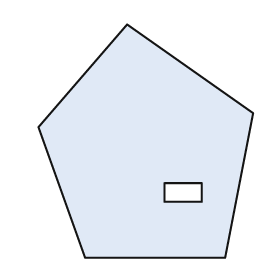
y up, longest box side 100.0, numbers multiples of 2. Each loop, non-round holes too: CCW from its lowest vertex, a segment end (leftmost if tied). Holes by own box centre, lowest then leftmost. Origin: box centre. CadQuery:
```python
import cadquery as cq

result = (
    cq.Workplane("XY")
    .moveTo(-26.0, -50.0)
    .lineTo(34.0, -50.0)
    .lineTo(46.0, 12.0)
    .lineTo(-8.0, 50.0)
    .lineTo(-46.0, 6.0)
    .close()
    .moveTo(8.0, -26.0)
    .lineTo(24.0, -26.0)
    .lineTo(24.0, -18.0)
    .lineTo(8.0, -18.0)
    .close()
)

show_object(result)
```